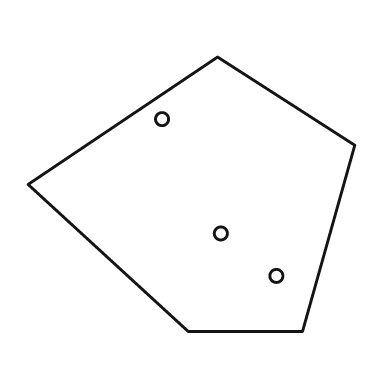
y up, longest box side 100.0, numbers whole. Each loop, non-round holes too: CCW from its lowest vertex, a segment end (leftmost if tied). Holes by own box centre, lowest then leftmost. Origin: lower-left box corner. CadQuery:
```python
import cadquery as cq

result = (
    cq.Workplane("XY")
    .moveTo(49.0, 0.0)
    .lineTo(84.0, 0.0)
    .lineTo(100.0, 57.0)
    .lineTo(58.0, 84.0)
    .lineTo(0.0, 45.0)
    .close()
    .moveTo(76.0, 17.0)
    .circle(2.0)
    .moveTo(59.0, 30.0)
    .circle(2.0)
    .moveTo(41.0, 65.0)
    .circle(2.0)
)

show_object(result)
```